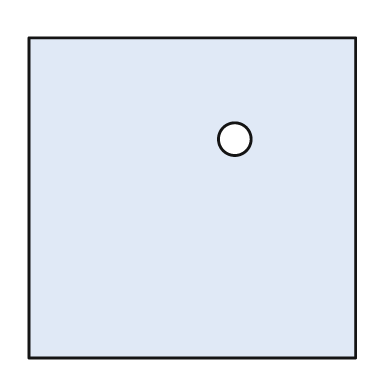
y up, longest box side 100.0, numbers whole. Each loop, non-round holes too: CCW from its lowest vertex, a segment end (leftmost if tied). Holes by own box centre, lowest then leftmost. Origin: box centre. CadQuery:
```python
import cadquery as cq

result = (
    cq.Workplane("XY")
    .moveTo(-50.0, -49.0)
    .lineTo(50.0, -49.0)
    .lineTo(50.0, 49.0)
    .lineTo(-50.0, 49.0)
    .close()
    .moveTo(13.0, 18.0)
    .circle(5.0)
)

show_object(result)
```